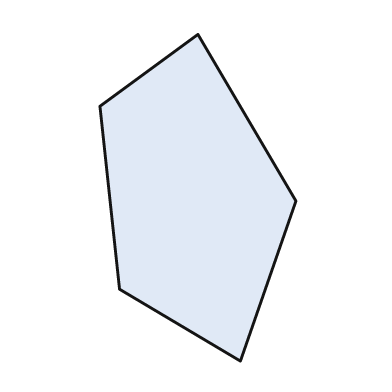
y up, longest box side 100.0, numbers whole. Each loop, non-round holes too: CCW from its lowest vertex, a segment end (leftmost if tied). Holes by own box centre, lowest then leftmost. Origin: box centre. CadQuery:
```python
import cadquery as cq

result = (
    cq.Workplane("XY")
    .moveTo(13.0, -50.0)
    .lineTo(30.0, -1.0)
    .lineTo(0.0, 50.0)
    .lineTo(-30.0, 28.0)
    .lineTo(-24.0, -28.0)
    .close()
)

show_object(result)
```